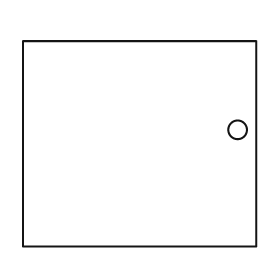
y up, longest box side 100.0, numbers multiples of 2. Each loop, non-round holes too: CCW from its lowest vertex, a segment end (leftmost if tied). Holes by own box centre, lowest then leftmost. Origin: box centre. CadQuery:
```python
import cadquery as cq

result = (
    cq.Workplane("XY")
    .moveTo(-50.0, -44.0)
    .lineTo(50.0, -44.0)
    .lineTo(50.0, 44.0)
    .lineTo(-50.0, 44.0)
    .close()
    .moveTo(42.0, 6.0)
    .circle(4.0)
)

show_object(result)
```